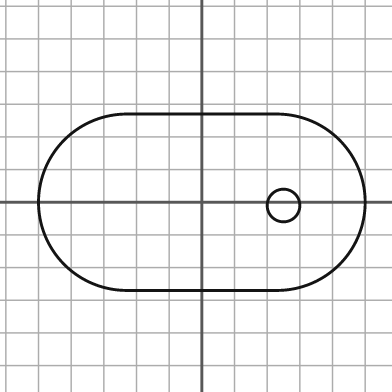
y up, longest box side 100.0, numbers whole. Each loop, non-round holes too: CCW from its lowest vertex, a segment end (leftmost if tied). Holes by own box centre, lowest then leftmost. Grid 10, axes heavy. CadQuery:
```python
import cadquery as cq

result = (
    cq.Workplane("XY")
    .moveTo(-23.0, -27.0)
    .lineTo(23.0, -27.0)
    .threePointArc((50.0, 0.0), (23.0, 27.0))
    .lineTo(-23.0, 27.0)
    .threePointArc((-50.0, 0.0), (-23.0, -27.0))
    .close()
    .moveTo(25.0, -1.0)
    .circle(5.0)
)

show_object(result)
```